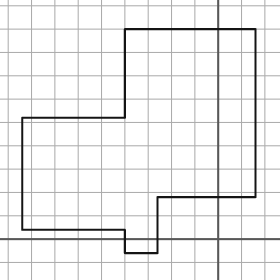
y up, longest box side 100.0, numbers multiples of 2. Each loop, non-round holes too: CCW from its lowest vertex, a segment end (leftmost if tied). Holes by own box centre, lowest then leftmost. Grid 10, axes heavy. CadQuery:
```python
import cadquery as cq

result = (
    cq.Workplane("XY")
    .moveTo(-40.0, -6.0)
    .lineTo(-26.0, -6.0)
    .lineTo(-26.0, 18.0)
    .lineTo(16.0, 18.0)
    .lineTo(16.0, 90.0)
    .lineTo(-40.0, 90.0)
    .lineTo(-40.0, 52.0)
    .lineTo(-84.0, 52.0)
    .lineTo(-84.0, 4.0)
    .lineTo(-40.0, 4.0)
    .close()
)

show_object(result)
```